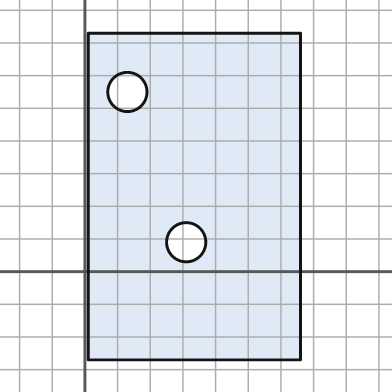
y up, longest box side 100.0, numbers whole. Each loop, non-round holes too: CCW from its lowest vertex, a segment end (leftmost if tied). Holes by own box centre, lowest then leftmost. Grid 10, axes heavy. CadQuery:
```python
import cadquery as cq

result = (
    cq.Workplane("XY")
    .moveTo(1.0, -27.0)
    .lineTo(66.0, -27.0)
    .lineTo(66.0, 73.0)
    .lineTo(1.0, 73.0)
    .close()
    .moveTo(31.0, 9.0)
    .circle(6.0)
    .moveTo(13.0, 55.0)
    .circle(6.0)
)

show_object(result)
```